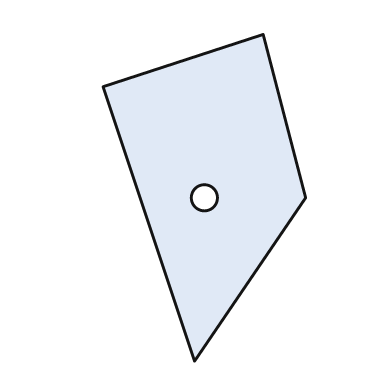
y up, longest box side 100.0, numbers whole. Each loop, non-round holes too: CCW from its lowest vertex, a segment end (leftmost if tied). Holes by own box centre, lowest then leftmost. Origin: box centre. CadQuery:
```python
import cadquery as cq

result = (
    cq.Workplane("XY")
    .moveTo(-3.0, -50.0)
    .lineTo(31.0, 0.0)
    .lineTo(18.0, 50.0)
    .lineTo(-31.0, 34.0)
    .close()
    .moveTo(0.0, 0.0)
    .circle(4.0)
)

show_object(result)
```